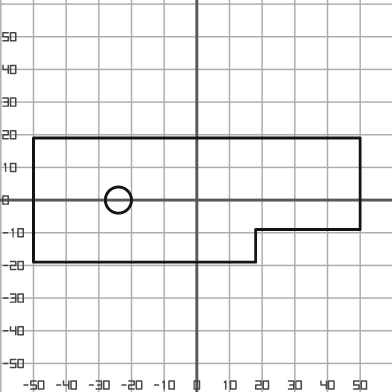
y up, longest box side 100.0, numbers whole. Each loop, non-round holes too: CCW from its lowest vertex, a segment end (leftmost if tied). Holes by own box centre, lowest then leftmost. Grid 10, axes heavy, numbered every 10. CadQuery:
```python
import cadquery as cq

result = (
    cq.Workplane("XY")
    .moveTo(-50.0, -19.0)
    .lineTo(18.0, -19.0)
    .lineTo(18.0, -9.0)
    .lineTo(50.0, -9.0)
    .lineTo(50.0, 19.0)
    .lineTo(-50.0, 19.0)
    .close()
    .moveTo(-24.0, 0.0)
    .circle(4.0)
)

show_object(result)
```